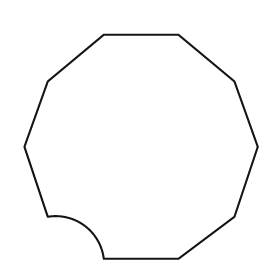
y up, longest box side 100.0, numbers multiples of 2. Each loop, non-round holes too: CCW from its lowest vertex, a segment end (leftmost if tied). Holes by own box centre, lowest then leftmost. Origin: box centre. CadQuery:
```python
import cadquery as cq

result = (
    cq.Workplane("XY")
    .moveTo(-16.0, -48.0)
    .lineTo(16.0, -48.0)
    .lineTo(40.0, -30.0)
    .lineTo(50.0, 0.0)
    .lineTo(40.0, 28.0)
    .lineTo(16.0, 48.0)
    .lineTo(-16.0, 48.0)
    .lineTo(-40.0, 28.0)
    .lineTo(-50.0, 0.0)
    .lineTo(-40.0, -30.0)
    .threePointArc((-24.0, -34.0), (-16.0, -48.0))
    .close()
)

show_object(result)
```